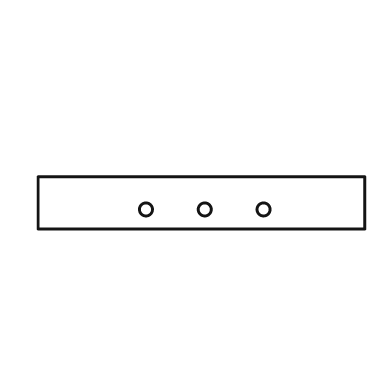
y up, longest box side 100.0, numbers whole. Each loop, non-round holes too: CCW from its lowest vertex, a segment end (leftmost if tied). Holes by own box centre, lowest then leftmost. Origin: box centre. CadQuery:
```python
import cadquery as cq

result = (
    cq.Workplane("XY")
    .moveTo(-50.0, -8.0)
    .lineTo(50.0, -8.0)
    .lineTo(50.0, 8.0)
    .lineTo(-50.0, 8.0)
    .close()
    .moveTo(-17.0, -2.0)
    .circle(2.0)
    .moveTo(1.0, -2.0)
    .circle(2.0)
    .moveTo(19.0, -2.0)
    .circle(2.0)
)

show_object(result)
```